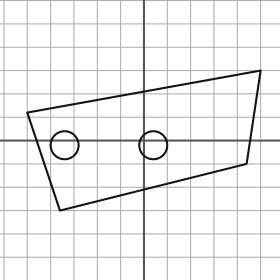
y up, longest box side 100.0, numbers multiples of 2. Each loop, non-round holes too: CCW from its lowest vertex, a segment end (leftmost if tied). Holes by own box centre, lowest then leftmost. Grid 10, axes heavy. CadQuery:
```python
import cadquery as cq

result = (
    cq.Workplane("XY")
    .moveTo(-36.0, -30.0)
    .lineTo(44.0, -10.0)
    .lineTo(50.0, 30.0)
    .lineTo(-50.0, 12.0)
    .close()
    .moveTo(-34.0, -2.0)
    .circle(6.0)
    .moveTo(4.0, -2.0)
    .circle(6.0)
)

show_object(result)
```